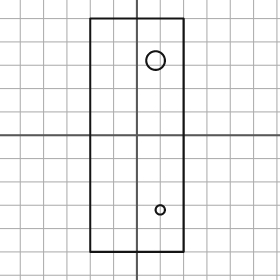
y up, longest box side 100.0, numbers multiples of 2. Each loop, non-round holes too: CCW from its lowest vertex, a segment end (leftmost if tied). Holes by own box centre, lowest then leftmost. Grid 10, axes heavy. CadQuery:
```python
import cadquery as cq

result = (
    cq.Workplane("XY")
    .moveTo(-20.0, -50.0)
    .lineTo(20.0, -50.0)
    .lineTo(20.0, 50.0)
    .lineTo(-20.0, 50.0)
    .close()
    .moveTo(10.0, -32.0)
    .circle(2.0)
    .moveTo(8.0, 32.0)
    .circle(4.0)
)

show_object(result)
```